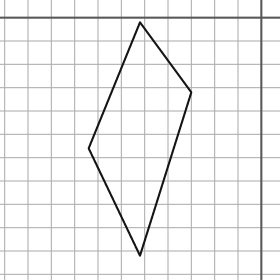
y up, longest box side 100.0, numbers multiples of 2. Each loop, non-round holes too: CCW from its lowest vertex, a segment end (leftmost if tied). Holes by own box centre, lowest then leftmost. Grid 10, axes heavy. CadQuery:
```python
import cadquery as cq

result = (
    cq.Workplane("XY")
    .moveTo(-52.0, -102.0)
    .lineTo(-30.0, -32.0)
    .lineTo(-52.0, -2.0)
    .lineTo(-74.0, -56.0)
    .close()
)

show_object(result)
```